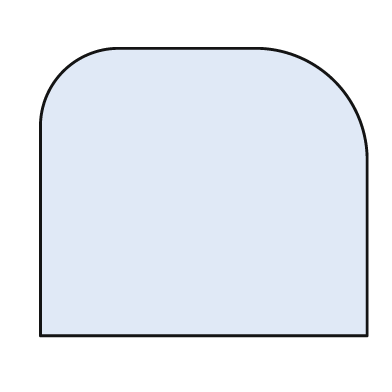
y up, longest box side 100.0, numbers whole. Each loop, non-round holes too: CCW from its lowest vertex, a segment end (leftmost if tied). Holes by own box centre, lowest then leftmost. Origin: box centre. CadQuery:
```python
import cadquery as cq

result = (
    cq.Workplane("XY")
    .moveTo(-50.0, -44.0)
    .lineTo(50.0, -44.0)
    .lineTo(50.0, 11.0)
    .threePointArc((40.0, 34.0), (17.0, 44.0))
    .lineTo(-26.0, 44.0)
    .threePointArc((-43.0, 37.0), (-50.0, 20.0))
    .close()
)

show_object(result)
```